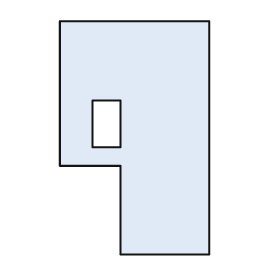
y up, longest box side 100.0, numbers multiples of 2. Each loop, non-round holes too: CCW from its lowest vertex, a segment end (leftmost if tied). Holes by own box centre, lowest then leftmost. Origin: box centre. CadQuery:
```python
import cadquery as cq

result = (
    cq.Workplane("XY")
    .moveTo(-6.0, -50.0)
    .lineTo(32.0, -50.0)
    .lineTo(32.0, 50.0)
    .lineTo(-32.0, 50.0)
    .lineTo(-32.0, -12.0)
    .lineTo(-6.0, -12.0)
    .close()
    .moveTo(-18.0, -4.0)
    .lineTo(-6.0, -4.0)
    .lineTo(-6.0, 16.0)
    .lineTo(-18.0, 16.0)
    .close()
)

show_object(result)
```